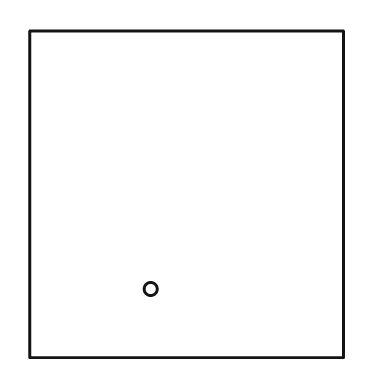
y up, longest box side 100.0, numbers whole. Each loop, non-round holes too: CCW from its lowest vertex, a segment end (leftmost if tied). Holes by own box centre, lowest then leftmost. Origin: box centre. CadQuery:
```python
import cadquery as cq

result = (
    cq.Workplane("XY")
    .moveTo(-48.0, -50.0)
    .lineTo(48.0, -50.0)
    .lineTo(48.0, 50.0)
    .lineTo(-48.0, 50.0)
    .close()
    .moveTo(-11.0, -29.0)
    .circle(2.0)
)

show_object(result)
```